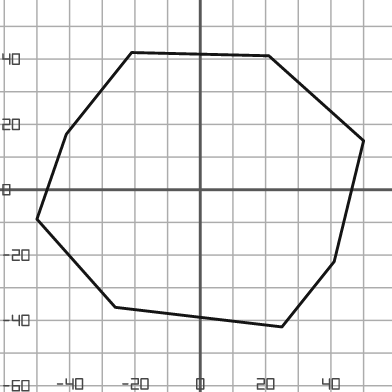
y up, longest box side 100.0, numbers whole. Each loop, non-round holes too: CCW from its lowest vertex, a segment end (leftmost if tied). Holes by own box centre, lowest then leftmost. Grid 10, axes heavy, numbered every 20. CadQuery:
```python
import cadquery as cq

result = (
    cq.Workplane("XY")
    .moveTo(25.0, -42.0)
    .lineTo(41.0, -22.0)
    .lineTo(50.0, 15.0)
    .lineTo(21.0, 41.0)
    .lineTo(-21.0, 42.0)
    .lineTo(-41.0, 17.0)
    .lineTo(-50.0, -9.0)
    .lineTo(-26.0, -36.0)
    .close()
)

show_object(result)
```